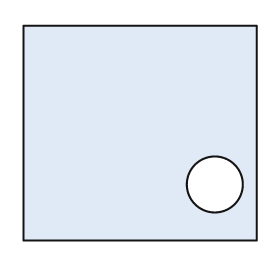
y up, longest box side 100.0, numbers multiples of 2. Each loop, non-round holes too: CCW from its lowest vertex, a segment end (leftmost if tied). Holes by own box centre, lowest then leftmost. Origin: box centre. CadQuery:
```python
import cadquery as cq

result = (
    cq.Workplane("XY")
    .moveTo(-50.0, -46.0)
    .lineTo(50.0, -46.0)
    .lineTo(50.0, 46.0)
    .lineTo(-50.0, 46.0)
    .close()
    .moveTo(32.0, -22.0)
    .circle(12.0)
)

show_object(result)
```